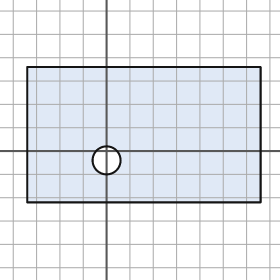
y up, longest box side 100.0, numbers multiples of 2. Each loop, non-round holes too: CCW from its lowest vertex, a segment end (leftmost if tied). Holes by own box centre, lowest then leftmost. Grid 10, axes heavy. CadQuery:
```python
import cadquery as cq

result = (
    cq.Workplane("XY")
    .moveTo(-34.0, -22.0)
    .lineTo(66.0, -22.0)
    .lineTo(66.0, 36.0)
    .lineTo(-34.0, 36.0)
    .close()
    .moveTo(0.0, -4.0)
    .circle(6.0)
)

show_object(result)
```